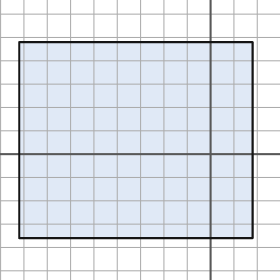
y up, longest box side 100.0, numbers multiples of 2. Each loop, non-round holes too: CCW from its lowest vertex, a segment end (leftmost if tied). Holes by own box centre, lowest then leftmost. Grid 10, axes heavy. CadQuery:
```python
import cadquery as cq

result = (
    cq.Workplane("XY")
    .moveTo(-82.0, -36.0)
    .lineTo(18.0, -36.0)
    .lineTo(18.0, 48.0)
    .lineTo(-82.0, 48.0)
    .close()
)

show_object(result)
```